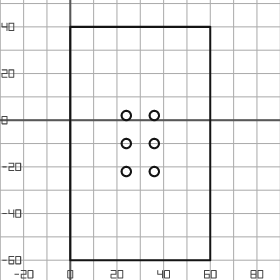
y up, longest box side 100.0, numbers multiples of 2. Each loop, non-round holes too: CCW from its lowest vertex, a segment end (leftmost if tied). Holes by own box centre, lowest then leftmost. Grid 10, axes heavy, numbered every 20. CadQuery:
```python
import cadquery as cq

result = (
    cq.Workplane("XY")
    .moveTo(0.0, -60.0)
    .lineTo(60.0, -60.0)
    .lineTo(60.0, 40.0)
    .lineTo(0.0, 40.0)
    .close()
    .moveTo(24.0, -22.0)
    .circle(2.0)
    .moveTo(36.0, -22.0)
    .circle(2.0)
    .moveTo(24.0, -10.0)
    .circle(2.0)
    .moveTo(36.0, -10.0)
    .circle(2.0)
    .moveTo(24.0, 2.0)
    .circle(2.0)
    .moveTo(36.0, 2.0)
    .circle(2.0)
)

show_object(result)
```